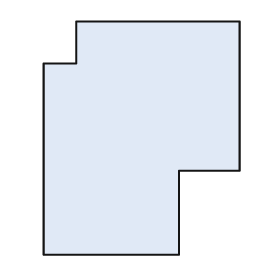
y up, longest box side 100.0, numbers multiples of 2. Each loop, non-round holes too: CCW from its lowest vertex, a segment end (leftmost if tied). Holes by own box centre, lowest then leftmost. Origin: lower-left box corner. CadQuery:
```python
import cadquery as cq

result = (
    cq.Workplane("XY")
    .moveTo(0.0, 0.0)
    .lineTo(58.0, 0.0)
    .lineTo(58.0, 36.0)
    .lineTo(84.0, 36.0)
    .lineTo(84.0, 100.0)
    .lineTo(14.0, 100.0)
    .lineTo(14.0, 82.0)
    .lineTo(0.0, 82.0)
    .close()
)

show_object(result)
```